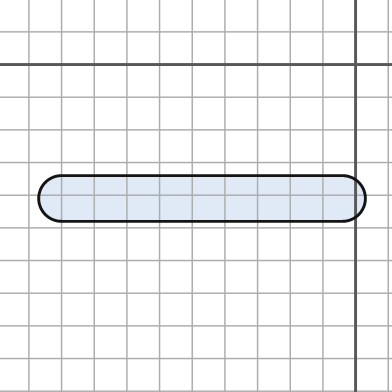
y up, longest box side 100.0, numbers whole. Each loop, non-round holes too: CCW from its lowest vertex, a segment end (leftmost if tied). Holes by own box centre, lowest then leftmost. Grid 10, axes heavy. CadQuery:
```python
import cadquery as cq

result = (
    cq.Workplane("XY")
    .moveTo(-90.0, -48.0)
    .lineTo(-4.0, -48.0)
    .threePointArc((3.0, -41.0), (-4.0, -34.0))
    .lineTo(-90.0, -34.0)
    .threePointArc((-97.0, -41.0), (-90.0, -48.0))
    .close()
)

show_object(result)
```